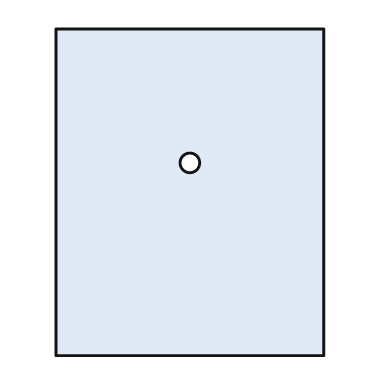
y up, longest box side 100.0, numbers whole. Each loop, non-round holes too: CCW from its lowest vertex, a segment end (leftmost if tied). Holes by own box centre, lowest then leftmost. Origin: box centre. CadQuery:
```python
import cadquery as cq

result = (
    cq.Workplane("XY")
    .moveTo(-41.0, -50.0)
    .lineTo(41.0, -50.0)
    .lineTo(41.0, 50.0)
    .lineTo(-41.0, 50.0)
    .close()
    .moveTo(0.0, 9.0)
    .circle(3.0)
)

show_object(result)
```